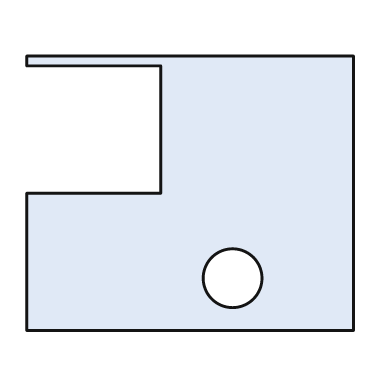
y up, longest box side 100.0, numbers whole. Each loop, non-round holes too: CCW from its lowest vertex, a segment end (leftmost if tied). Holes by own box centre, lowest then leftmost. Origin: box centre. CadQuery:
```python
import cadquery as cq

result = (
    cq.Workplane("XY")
    .moveTo(-50.0, -42.0)
    .lineTo(50.0, -42.0)
    .lineTo(50.0, 42.0)
    .lineTo(-50.0, 42.0)
    .lineTo(-50.0, 39.0)
    .lineTo(-9.0, 39.0)
    .lineTo(-9.0, 0.0)
    .lineTo(-50.0, 0.0)
    .close()
    .moveTo(13.0, -26.0)
    .circle(9.0)
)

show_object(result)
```